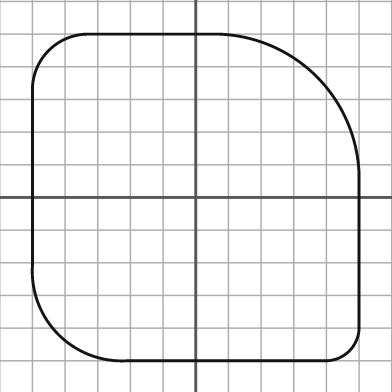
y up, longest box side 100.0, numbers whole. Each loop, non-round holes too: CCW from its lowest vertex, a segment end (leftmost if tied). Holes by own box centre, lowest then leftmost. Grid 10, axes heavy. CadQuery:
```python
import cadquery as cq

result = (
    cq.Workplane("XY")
    .moveTo(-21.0, -50.0)
    .lineTo(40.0, -50.0)
    .threePointArc((47.0, -47.0), (50.0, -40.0))
    .lineTo(50.0, 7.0)
    .threePointArc((37.0, 37.0), (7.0, 50.0))
    .lineTo(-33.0, 50.0)
    .threePointArc((-45.0, 45.0), (-50.0, 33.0))
    .lineTo(-50.0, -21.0)
    .threePointArc((-42.0, -42.0), (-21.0, -50.0))
    .close()
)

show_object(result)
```